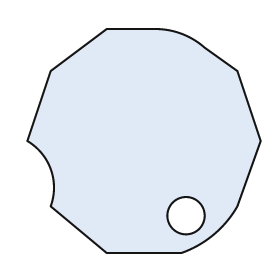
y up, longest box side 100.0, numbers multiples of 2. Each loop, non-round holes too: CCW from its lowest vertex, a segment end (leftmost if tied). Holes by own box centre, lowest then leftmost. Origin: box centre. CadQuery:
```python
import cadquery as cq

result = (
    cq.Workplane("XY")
    .moveTo(-16.0, -48.0)
    .lineTo(16.0, -48.0)
    .threePointArc((30.0, -40.0), (40.0, -28.0))
    .lineTo(50.0, 0.0)
    .lineTo(40.0, 30.0)
    .lineTo(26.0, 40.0)
    .threePointArc((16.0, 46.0), (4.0, 48.0))
    .lineTo(-16.0, 48.0)
    .lineTo(-40.0, 30.0)
    .lineTo(-50.0, 0.0)
    .threePointArc((-40.0, -12.0), (-40.0, -28.0))
    .close()
    .moveTo(18.0, -32.0)
    .circle(8.0)
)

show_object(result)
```